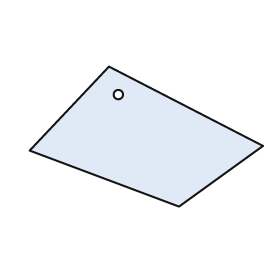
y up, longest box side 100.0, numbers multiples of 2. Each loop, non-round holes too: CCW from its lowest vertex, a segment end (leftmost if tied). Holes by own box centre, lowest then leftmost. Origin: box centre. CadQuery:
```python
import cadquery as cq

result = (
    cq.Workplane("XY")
    .moveTo(14.0, -30.0)
    .lineTo(50.0, -4.0)
    .lineTo(-16.0, 30.0)
    .lineTo(-50.0, -6.0)
    .close()
    .moveTo(-12.0, 18.0)
    .circle(2.0)
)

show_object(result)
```